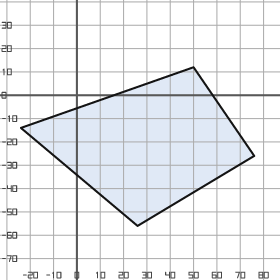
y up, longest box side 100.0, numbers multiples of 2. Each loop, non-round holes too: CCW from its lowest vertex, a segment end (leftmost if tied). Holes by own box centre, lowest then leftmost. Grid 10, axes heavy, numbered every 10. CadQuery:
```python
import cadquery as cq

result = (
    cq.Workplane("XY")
    .moveTo(26.0, -56.0)
    .lineTo(76.0, -26.0)
    .lineTo(50.0, 12.0)
    .lineTo(-24.0, -14.0)
    .close()
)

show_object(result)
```